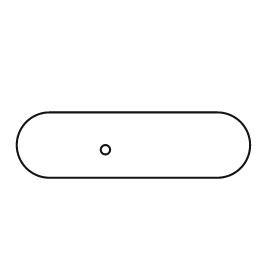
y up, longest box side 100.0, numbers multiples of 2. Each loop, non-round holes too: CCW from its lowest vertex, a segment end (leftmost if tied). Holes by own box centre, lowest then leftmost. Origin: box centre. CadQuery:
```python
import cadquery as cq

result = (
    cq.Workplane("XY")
    .moveTo(-36.0, -14.0)
    .lineTo(36.0, -14.0)
    .threePointArc((50.0, 0.0), (36.0, 14.0))
    .lineTo(-36.0, 14.0)
    .threePointArc((-50.0, 0.0), (-36.0, -14.0))
    .close()
    .moveTo(-12.0, -2.0)
    .circle(2.0)
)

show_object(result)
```